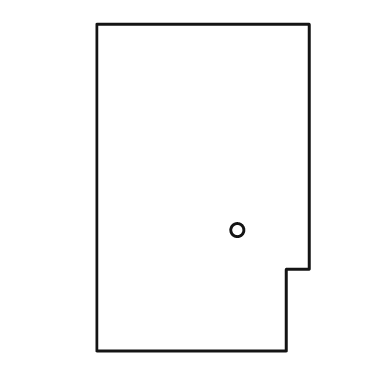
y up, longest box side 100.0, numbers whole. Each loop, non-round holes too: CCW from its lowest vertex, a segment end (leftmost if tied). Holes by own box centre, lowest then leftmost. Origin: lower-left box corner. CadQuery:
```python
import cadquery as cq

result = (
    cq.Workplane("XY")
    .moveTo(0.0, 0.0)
    .lineTo(58.0, 0.0)
    .lineTo(58.0, 25.0)
    .lineTo(65.0, 25.0)
    .lineTo(65.0, 100.0)
    .lineTo(0.0, 100.0)
    .close()
    .moveTo(43.0, 37.0)
    .circle(2.0)
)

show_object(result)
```